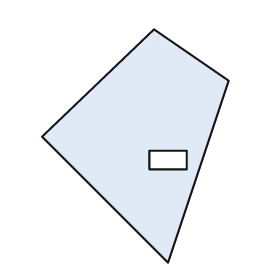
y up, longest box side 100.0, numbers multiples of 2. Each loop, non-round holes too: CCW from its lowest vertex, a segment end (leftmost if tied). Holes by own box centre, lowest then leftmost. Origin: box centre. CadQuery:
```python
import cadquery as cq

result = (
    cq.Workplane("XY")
    .moveTo(14.0, -50.0)
    .lineTo(40.0, 28.0)
    .lineTo(8.0, 50.0)
    .lineTo(-40.0, 4.0)
    .close()
    .moveTo(6.0, -10.0)
    .lineTo(22.0, -10.0)
    .lineTo(22.0, -2.0)
    .lineTo(6.0, -2.0)
    .close()
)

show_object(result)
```